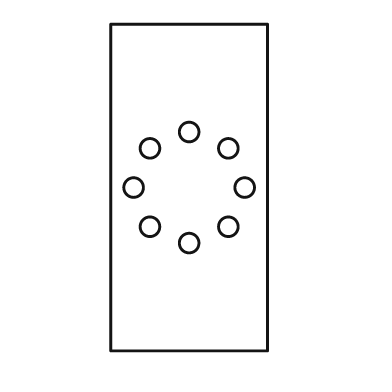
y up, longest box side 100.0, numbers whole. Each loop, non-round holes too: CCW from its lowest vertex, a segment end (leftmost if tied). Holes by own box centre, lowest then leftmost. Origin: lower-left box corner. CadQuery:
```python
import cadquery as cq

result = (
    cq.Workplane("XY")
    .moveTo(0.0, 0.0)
    .lineTo(48.0, 0.0)
    .lineTo(48.0, 100.0)
    .lineTo(0.0, 100.0)
    .close()
    .moveTo(24.0, 33.0)
    .circle(3.0)
    .moveTo(12.0, 38.0)
    .circle(3.0)
    .moveTo(36.0, 38.0)
    .circle(3.0)
    .moveTo(7.0, 50.0)
    .circle(3.0)
    .moveTo(41.0, 50.0)
    .circle(3.0)
    .moveTo(12.0, 62.0)
    .circle(3.0)
    .moveTo(36.0, 62.0)
    .circle(3.0)
    .moveTo(24.0, 67.0)
    .circle(3.0)
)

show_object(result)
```